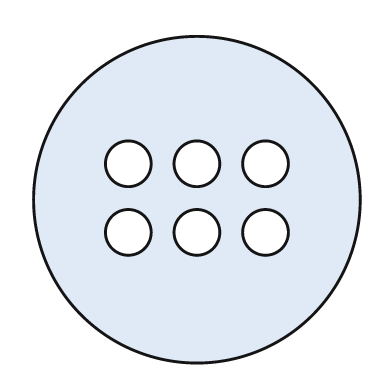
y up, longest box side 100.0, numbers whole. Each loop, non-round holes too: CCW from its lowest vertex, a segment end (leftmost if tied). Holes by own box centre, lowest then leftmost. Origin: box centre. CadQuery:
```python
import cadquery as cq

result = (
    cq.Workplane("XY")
    .moveTo(0.0, 0.0)
    .circle(50.0)
    .moveTo(-21.0, -10.0)
    .circle(7.0)
    .moveTo(0.0, -10.0)
    .circle(7.0)
    .moveTo(21.0, -10.0)
    .circle(7.0)
    .moveTo(-21.0, 11.0)
    .circle(7.0)
    .moveTo(0.0, 11.0)
    .circle(7.0)
    .moveTo(21.0, 11.0)
    .circle(7.0)
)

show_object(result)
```